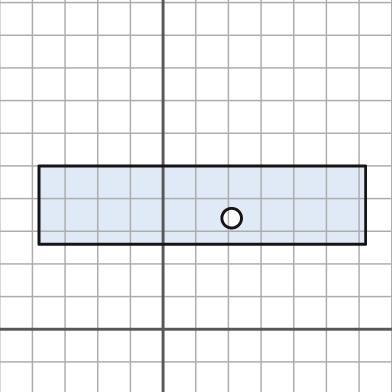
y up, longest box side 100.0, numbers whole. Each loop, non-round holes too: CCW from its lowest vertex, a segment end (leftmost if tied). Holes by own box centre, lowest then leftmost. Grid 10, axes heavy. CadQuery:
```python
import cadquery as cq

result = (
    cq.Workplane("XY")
    .moveTo(-38.0, 26.0)
    .lineTo(62.0, 26.0)
    .lineTo(62.0, 50.0)
    .lineTo(-38.0, 50.0)
    .close()
    .moveTo(21.0, 34.0)
    .circle(3.0)
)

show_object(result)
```